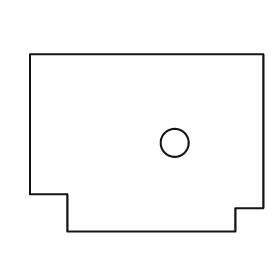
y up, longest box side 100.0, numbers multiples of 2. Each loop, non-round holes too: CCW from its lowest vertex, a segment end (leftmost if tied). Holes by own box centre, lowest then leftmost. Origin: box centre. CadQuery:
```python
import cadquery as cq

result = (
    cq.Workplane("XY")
    .moveTo(-34.0, -38.0)
    .lineTo(38.0, -38.0)
    .lineTo(38.0, -28.0)
    .lineTo(50.0, -28.0)
    .lineTo(50.0, 38.0)
    .lineTo(-50.0, 38.0)
    .lineTo(-50.0, -22.0)
    .lineTo(-34.0, -22.0)
    .close()
    .moveTo(12.0, 0.0)
    .circle(6.0)
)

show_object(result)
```